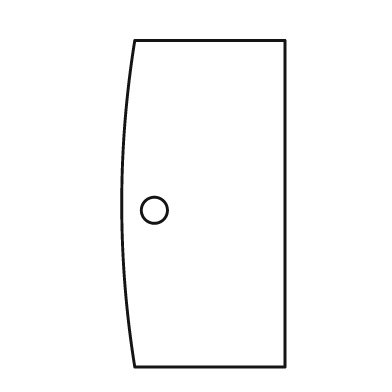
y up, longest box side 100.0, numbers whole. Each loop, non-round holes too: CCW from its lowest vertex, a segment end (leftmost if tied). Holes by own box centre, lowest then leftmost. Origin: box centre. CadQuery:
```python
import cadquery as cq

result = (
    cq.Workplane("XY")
    .moveTo(-21.0, -50.0)
    .lineTo(25.0, -50.0)
    .lineTo(25.0, 50.0)
    .lineTo(-21.0, 50.0)
    .threePointArc((-25.0, 0.0), (-21.0, -50.0))
    .close()
    .moveTo(-15.0, -2.0)
    .circle(4.0)
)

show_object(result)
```